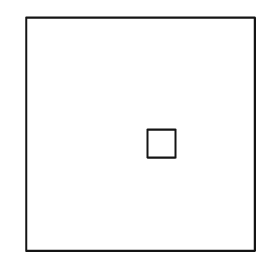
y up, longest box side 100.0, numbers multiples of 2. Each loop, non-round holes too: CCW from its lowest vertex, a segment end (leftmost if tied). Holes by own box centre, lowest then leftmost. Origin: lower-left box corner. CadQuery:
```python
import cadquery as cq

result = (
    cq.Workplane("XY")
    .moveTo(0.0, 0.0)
    .lineTo(98.0, 0.0)
    .lineTo(98.0, 100.0)
    .lineTo(0.0, 100.0)
    .close()
    .moveTo(52.0, 40.0)
    .lineTo(64.0, 40.0)
    .lineTo(64.0, 52.0)
    .lineTo(52.0, 52.0)
    .close()
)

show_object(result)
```